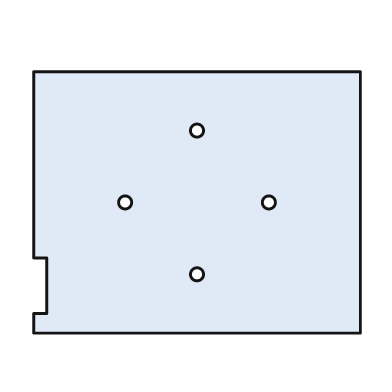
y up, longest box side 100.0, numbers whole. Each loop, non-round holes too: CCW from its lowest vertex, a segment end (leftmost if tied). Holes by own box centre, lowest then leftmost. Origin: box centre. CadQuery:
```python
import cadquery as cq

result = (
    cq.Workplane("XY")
    .moveTo(-50.0, -40.0)
    .lineTo(50.0, -40.0)
    .lineTo(50.0, 40.0)
    .lineTo(-50.0, 40.0)
    .lineTo(-50.0, -17.0)
    .lineTo(-46.0, -17.0)
    .lineTo(-46.0, -34.0)
    .lineTo(-50.0, -34.0)
    .close()
    .moveTo(0.0, -22.0)
    .circle(2.0)
    .moveTo(-22.0, 0.0)
    .circle(2.0)
    .moveTo(22.0, 0.0)
    .circle(2.0)
    .moveTo(0.0, 22.0)
    .circle(2.0)
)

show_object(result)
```